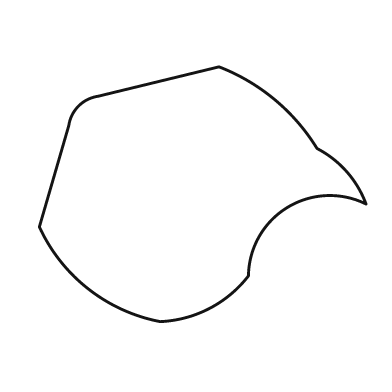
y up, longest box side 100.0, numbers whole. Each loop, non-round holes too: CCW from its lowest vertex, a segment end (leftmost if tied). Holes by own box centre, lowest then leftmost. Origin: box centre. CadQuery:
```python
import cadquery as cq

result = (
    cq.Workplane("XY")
    .moveTo(-13.0, -39.0)
    .threePointArc((2.0, -35.0), (14.0, -25.0))
    .threePointArc((26.0, -4.0), (50.0, -3.0))
    .threePointArc((44.0, 7.0), (35.0, 14.0))
    .threePointArc((22.0, 29.0), (5.0, 39.0))
    .lineTo(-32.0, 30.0)
    .threePointArc((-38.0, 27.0), (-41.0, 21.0))
    .lineTo(-50.0, -10.0)
    .threePointArc((-35.0, -29.0), (-13.0, -39.0))
    .close()
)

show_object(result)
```